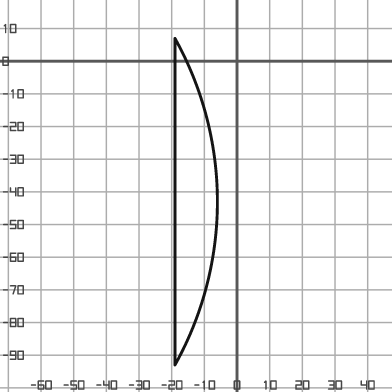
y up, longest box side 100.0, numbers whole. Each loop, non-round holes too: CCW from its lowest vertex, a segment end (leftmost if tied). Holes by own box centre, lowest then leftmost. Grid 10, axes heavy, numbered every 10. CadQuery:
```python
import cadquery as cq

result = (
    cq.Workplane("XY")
    .moveTo(-19.0, -93.0)
    .threePointArc((-6.0, -43.0), (-19.0, 7.0))
    .close()
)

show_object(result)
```